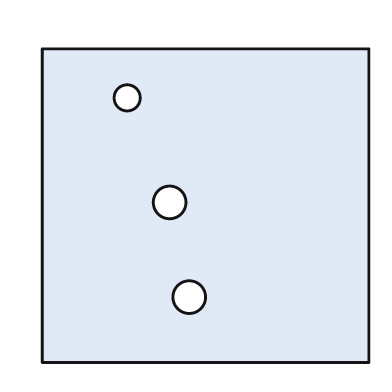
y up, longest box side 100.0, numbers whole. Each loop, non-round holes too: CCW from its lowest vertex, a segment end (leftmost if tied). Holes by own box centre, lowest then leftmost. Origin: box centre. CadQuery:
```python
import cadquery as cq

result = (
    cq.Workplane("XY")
    .moveTo(-50.0, -48.0)
    .lineTo(50.0, -48.0)
    .lineTo(50.0, 48.0)
    .lineTo(-50.0, 48.0)
    .close()
    .moveTo(-5.0, -28.0)
    .circle(5.0)
    .moveTo(-11.0, 1.0)
    .circle(5.0)
    .moveTo(-24.0, 33.0)
    .circle(4.0)
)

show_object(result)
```